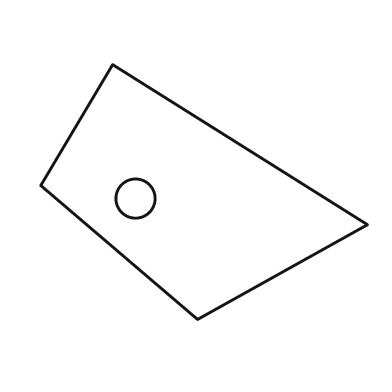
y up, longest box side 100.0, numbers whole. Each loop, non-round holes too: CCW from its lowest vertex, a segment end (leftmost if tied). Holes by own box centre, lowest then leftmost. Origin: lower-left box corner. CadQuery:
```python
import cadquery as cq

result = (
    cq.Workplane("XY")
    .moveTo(48.0, 0.0)
    .lineTo(100.0, 29.0)
    .lineTo(22.0, 78.0)
    .lineTo(0.0, 41.0)
    .close()
    .moveTo(29.0, 37.0)
    .circle(6.0)
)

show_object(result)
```